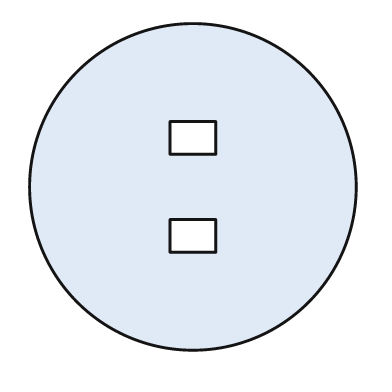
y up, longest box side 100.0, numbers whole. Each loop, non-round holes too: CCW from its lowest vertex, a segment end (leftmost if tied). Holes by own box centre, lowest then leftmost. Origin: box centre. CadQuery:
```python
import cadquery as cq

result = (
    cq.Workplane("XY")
    .moveTo(0.0, 0.0)
    .circle(50.0)
    .moveTo(-7.0, -20.0)
    .lineTo(7.0, -20.0)
    .lineTo(7.0, -10.0)
    .lineTo(-7.0, -10.0)
    .close()
    .moveTo(-7.0, 10.0)
    .lineTo(7.0, 10.0)
    .lineTo(7.0, 20.0)
    .lineTo(-7.0, 20.0)
    .close()
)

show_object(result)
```